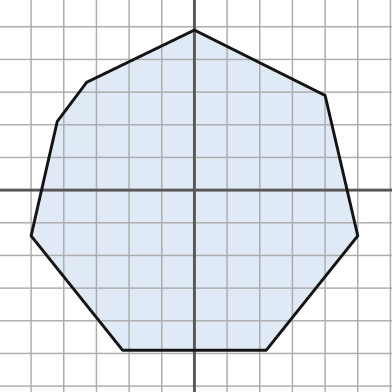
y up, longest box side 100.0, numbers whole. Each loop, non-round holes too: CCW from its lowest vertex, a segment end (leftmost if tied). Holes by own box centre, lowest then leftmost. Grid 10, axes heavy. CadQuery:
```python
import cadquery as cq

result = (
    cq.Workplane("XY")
    .moveTo(-22.0, -49.0)
    .lineTo(22.0, -49.0)
    .lineTo(50.0, -14.0)
    .lineTo(40.0, 29.0)
    .lineTo(0.0, 49.0)
    .lineTo(-33.0, 33.0)
    .lineTo(-42.0, 21.0)
    .lineTo(-50.0, -14.0)
    .close()
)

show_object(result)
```